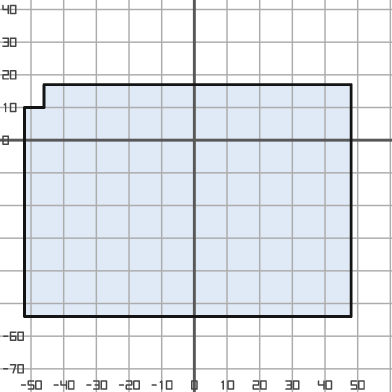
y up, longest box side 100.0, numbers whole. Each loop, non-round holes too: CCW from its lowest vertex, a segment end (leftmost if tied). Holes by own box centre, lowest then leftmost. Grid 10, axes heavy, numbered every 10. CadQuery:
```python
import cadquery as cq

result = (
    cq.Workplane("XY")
    .moveTo(-52.0, -54.0)
    .lineTo(48.0, -54.0)
    .lineTo(48.0, 17.0)
    .lineTo(-46.0, 17.0)
    .lineTo(-46.0, 10.0)
    .lineTo(-52.0, 10.0)
    .close()
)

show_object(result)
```